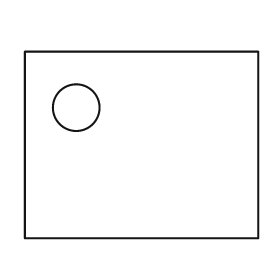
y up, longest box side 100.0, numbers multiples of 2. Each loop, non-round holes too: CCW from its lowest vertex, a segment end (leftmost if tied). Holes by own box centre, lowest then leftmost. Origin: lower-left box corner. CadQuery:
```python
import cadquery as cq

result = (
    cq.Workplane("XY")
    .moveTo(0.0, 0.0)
    .lineTo(100.0, 0.0)
    .lineTo(100.0, 80.0)
    .lineTo(0.0, 80.0)
    .close()
    .moveTo(22.0, 56.0)
    .circle(10.0)
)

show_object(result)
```